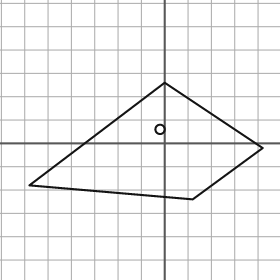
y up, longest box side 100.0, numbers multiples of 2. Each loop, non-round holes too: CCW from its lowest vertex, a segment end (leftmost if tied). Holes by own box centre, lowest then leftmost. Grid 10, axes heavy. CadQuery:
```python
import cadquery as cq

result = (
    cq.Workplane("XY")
    .moveTo(12.0, -24.0)
    .lineTo(42.0, -2.0)
    .lineTo(0.0, 26.0)
    .lineTo(-58.0, -18.0)
    .close()
    .moveTo(-2.0, 6.0)
    .circle(2.0)
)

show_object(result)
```